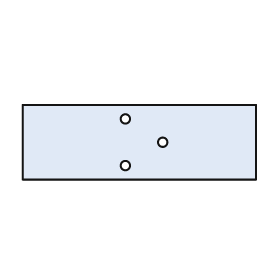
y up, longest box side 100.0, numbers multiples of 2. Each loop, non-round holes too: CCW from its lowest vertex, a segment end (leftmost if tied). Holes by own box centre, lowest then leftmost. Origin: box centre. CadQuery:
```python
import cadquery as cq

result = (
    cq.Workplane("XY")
    .moveTo(-50.0, -16.0)
    .lineTo(50.0, -16.0)
    .lineTo(50.0, 16.0)
    .lineTo(-50.0, 16.0)
    .close()
    .moveTo(-6.0, -10.0)
    .circle(2.0)
    .moveTo(10.0, 0.0)
    .circle(2.0)
    .moveTo(-6.0, 10.0)
    .circle(2.0)
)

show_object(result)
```